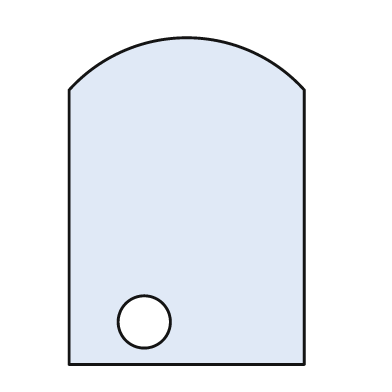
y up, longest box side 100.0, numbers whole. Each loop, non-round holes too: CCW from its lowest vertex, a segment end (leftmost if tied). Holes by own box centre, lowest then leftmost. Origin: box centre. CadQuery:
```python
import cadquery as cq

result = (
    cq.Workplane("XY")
    .moveTo(-36.0, -50.0)
    .lineTo(36.0, -50.0)
    .lineTo(36.0, 34.0)
    .threePointArc((0.0, 50.0), (-36.0, 34.0))
    .close()
    .moveTo(-13.0, -37.0)
    .circle(8.0)
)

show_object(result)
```